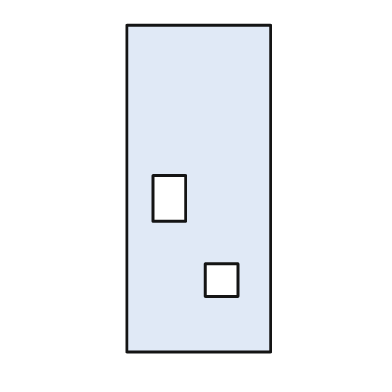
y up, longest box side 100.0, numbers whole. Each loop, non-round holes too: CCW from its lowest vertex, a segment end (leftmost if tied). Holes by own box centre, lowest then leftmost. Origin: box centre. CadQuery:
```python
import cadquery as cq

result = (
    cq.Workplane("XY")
    .moveTo(-22.0, -50.0)
    .lineTo(22.0, -50.0)
    .lineTo(22.0, 50.0)
    .lineTo(-22.0, 50.0)
    .close()
    .moveTo(2.0, -33.0)
    .lineTo(12.0, -33.0)
    .lineTo(12.0, -23.0)
    .lineTo(2.0, -23.0)
    .close()
    .moveTo(-14.0, -10.0)
    .lineTo(-4.0, -10.0)
    .lineTo(-4.0, 4.0)
    .lineTo(-14.0, 4.0)
    .close()
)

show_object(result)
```